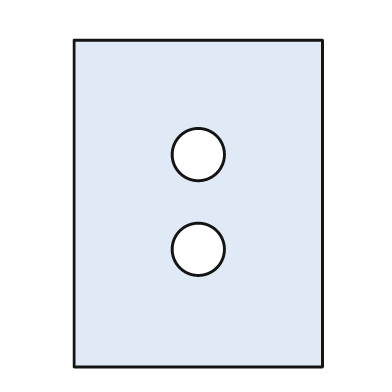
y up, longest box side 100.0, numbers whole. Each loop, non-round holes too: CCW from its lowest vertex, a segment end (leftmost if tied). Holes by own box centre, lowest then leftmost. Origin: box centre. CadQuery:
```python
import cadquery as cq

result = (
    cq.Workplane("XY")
    .moveTo(-38.0, -50.0)
    .lineTo(38.0, -50.0)
    .lineTo(38.0, 50.0)
    .lineTo(-38.0, 50.0)
    .close()
    .moveTo(0.0, -14.0)
    .circle(8.0)
    .moveTo(0.0, 15.0)
    .circle(8.0)
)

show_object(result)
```